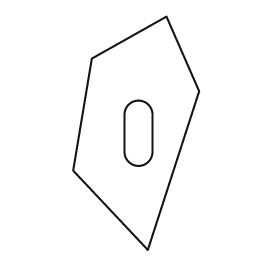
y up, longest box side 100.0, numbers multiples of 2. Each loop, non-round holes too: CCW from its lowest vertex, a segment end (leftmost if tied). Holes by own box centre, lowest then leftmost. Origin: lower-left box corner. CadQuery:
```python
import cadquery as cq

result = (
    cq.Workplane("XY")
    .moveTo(32.0, 0.0)
    .lineTo(54.0, 68.0)
    .lineTo(40.0, 100.0)
    .lineTo(8.0, 82.0)
    .lineTo(0.0, 34.0)
    .close()
    .moveTo(22.0, 42.0)
    .threePointArc((28.0, 36.0), (34.0, 42.0))
    .lineTo(34.0, 58.0)
    .threePointArc((28.0, 64.0), (22.0, 58.0))
    .close()
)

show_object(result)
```